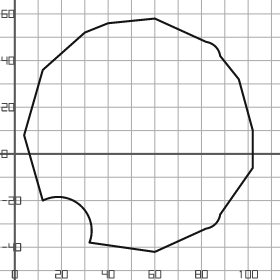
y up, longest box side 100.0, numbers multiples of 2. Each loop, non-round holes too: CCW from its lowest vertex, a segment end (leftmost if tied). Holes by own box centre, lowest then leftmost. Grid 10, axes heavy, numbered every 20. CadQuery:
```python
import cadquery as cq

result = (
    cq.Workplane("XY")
    .moveTo(60.0, -42.0)
    .lineTo(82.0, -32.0)
    .threePointArc((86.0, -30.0), (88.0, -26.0))
    .lineTo(102.0, -6.0)
    .lineTo(102.0, 10.0)
    .lineTo(96.0, 32.0)
    .lineTo(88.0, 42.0)
    .threePointArc((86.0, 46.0), (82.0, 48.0))
    .lineTo(60.0, 58.0)
    .lineTo(40.0, 56.0)
    .lineTo(30.0, 52.0)
    .lineTo(12.0, 36.0)
    .lineTo(4.0, 8.0)
    .lineTo(12.0, -20.0)
    .threePointArc((28.0, -22.0), (32.0, -38.0))
    .close()
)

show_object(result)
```